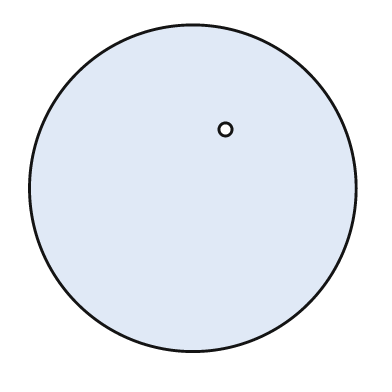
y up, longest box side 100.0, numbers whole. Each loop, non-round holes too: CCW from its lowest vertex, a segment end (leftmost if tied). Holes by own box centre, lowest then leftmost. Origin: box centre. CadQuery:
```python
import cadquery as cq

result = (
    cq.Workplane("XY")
    .moveTo(0.0, 0.0)
    .circle(50.0)
    .moveTo(10.0, 18.0)
    .circle(2.0)
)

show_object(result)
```